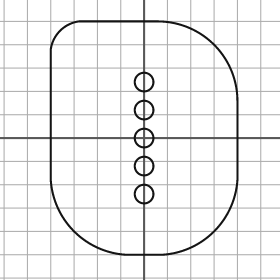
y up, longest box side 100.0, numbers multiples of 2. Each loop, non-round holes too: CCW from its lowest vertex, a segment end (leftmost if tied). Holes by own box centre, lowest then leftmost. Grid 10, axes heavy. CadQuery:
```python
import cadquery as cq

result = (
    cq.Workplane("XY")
    .moveTo(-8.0, -50.0)
    .lineTo(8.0, -50.0)
    .threePointArc((30.0, -40.0), (40.0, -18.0))
    .lineTo(40.0, 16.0)
    .threePointArc((30.0, 40.0), (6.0, 50.0))
    .lineTo(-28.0, 50.0)
    .threePointArc((-36.0, 46.0), (-40.0, 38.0))
    .lineTo(-40.0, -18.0)
    .threePointArc((-30.0, -40.0), (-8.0, -50.0))
    .close()
    .moveTo(0.0, -24.0)
    .circle(4.0)
    .moveTo(0.0, -12.0)
    .circle(4.0)
    .moveTo(0.0, 0.0)
    .circle(4.0)
    .moveTo(0.0, 12.0)
    .circle(4.0)
    .moveTo(0.0, 24.0)
    .circle(4.0)
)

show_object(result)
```